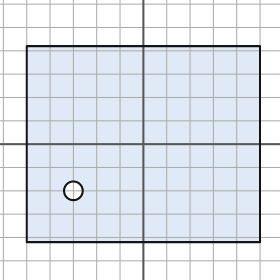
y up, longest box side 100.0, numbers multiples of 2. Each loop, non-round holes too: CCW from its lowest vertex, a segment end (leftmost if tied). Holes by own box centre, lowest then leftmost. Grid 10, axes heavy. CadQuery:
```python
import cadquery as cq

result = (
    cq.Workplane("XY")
    .moveTo(-50.0, -42.0)
    .lineTo(50.0, -42.0)
    .lineTo(50.0, 42.0)
    .lineTo(-50.0, 42.0)
    .close()
    .moveTo(-30.0, -20.0)
    .circle(4.0)
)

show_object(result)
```